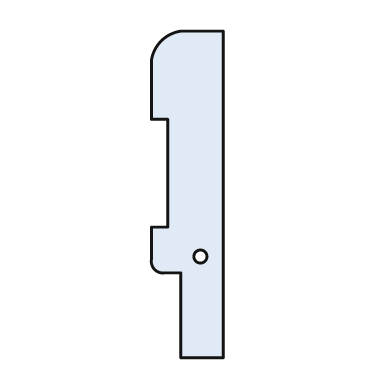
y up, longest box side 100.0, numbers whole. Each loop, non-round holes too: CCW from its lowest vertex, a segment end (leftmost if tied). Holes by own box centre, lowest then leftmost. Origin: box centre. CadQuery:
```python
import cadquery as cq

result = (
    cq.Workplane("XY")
    .moveTo(-2.0, -50.0)
    .lineTo(11.0, -50.0)
    .lineTo(11.0, 50.0)
    .lineTo(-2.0, 50.0)
    .threePointArc((-8.0, 47.0), (-11.0, 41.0))
    .lineTo(-11.0, 23.0)
    .lineTo(-6.0, 23.0)
    .lineTo(-6.0, -10.0)
    .lineTo(-11.0, -10.0)
    .lineTo(-11.0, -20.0)
    .threePointArc((-10.0, -23.0), (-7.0, -24.0))
    .lineTo(-2.0, -24.0)
    .close()
    .moveTo(4.0, -19.0)
    .circle(2.0)
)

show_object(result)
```